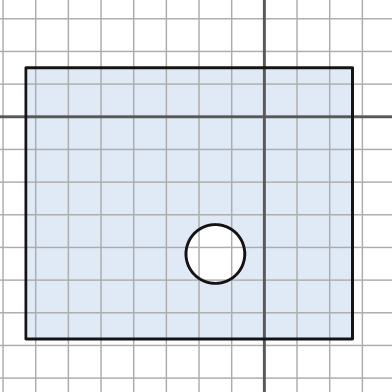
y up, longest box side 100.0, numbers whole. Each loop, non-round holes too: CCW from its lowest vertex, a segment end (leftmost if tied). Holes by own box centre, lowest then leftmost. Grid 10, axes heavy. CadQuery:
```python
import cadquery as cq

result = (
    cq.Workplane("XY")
    .moveTo(-73.0, -68.0)
    .lineTo(27.0, -68.0)
    .lineTo(27.0, 15.0)
    .lineTo(-73.0, 15.0)
    .close()
    .moveTo(-15.0, -42.0)
    .circle(9.0)
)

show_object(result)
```